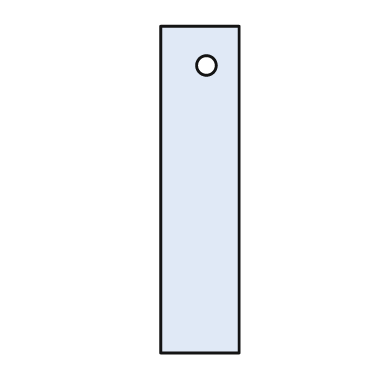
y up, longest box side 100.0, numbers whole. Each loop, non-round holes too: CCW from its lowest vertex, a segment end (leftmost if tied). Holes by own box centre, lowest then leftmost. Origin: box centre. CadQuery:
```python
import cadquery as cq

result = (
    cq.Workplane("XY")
    .moveTo(-12.0, -50.0)
    .lineTo(12.0, -50.0)
    .lineTo(12.0, 50.0)
    .lineTo(-12.0, 50.0)
    .close()
    .moveTo(2.0, 38.0)
    .circle(3.0)
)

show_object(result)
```